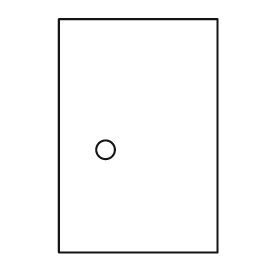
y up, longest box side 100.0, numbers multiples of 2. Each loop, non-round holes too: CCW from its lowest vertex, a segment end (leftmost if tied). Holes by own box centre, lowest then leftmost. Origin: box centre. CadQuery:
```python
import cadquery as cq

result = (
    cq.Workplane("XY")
    .moveTo(-34.0, -50.0)
    .lineTo(34.0, -50.0)
    .lineTo(34.0, 50.0)
    .lineTo(-34.0, 50.0)
    .close()
    .moveTo(-14.0, -6.0)
    .circle(4.0)
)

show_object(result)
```